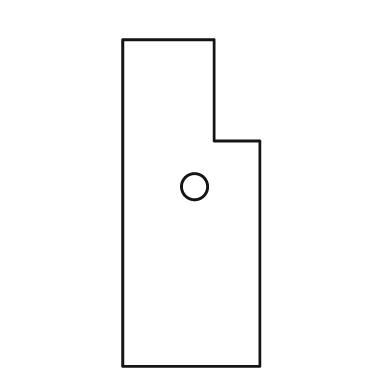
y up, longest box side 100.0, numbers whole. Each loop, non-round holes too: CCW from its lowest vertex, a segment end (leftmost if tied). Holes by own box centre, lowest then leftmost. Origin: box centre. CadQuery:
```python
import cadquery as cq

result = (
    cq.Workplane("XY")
    .moveTo(-21.0, -50.0)
    .lineTo(21.0, -50.0)
    .lineTo(21.0, 19.0)
    .lineTo(7.0, 19.0)
    .lineTo(7.0, 50.0)
    .lineTo(-21.0, 50.0)
    .close()
    .moveTo(1.0, 5.0)
    .circle(4.0)
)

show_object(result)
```